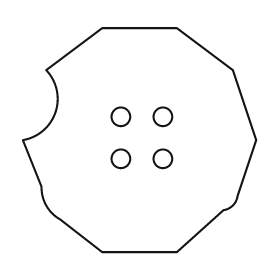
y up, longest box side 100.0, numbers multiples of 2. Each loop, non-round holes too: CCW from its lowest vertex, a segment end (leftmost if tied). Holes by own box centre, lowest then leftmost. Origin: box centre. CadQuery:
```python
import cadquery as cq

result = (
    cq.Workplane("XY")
    .moveTo(-16.0, -48.0)
    .lineTo(16.0, -48.0)
    .lineTo(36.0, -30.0)
    .threePointArc((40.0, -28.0), (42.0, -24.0))
    .lineTo(50.0, 0.0)
    .lineTo(40.0, 30.0)
    .lineTo(16.0, 48.0)
    .lineTo(-16.0, 48.0)
    .lineTo(-40.0, 30.0)
    .threePointArc((-36.0, 12.0), (-50.0, 0.0))
    .lineTo(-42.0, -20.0)
    .threePointArc((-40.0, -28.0), (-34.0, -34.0))
    .close()
    .moveTo(-8.0, -8.0)
    .circle(4.0)
    .moveTo(10.0, -8.0)
    .circle(4.0)
    .moveTo(-8.0, 10.0)
    .circle(4.0)
    .moveTo(10.0, 10.0)
    .circle(4.0)
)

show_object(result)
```